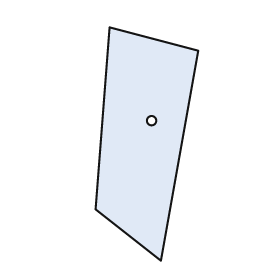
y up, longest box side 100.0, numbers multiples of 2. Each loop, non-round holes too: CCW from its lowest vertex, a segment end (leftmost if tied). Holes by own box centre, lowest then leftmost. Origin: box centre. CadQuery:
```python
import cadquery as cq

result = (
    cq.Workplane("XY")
    .moveTo(6.0, -50.0)
    .lineTo(22.0, 40.0)
    .lineTo(-16.0, 50.0)
    .lineTo(-22.0, -28.0)
    .close()
    .moveTo(2.0, 10.0)
    .circle(2.0)
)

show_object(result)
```